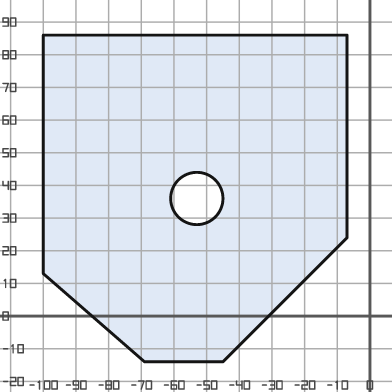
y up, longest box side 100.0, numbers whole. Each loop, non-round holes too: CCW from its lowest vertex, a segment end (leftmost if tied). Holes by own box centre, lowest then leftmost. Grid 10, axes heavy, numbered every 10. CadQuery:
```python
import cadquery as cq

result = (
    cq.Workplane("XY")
    .moveTo(-69.0, -14.0)
    .lineTo(-45.0, -14.0)
    .lineTo(-7.0, 24.0)
    .lineTo(-7.0, 86.0)
    .lineTo(-100.0, 86.0)
    .lineTo(-100.0, 13.0)
    .close()
    .moveTo(-53.0, 36.0)
    .circle(8.0)
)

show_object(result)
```